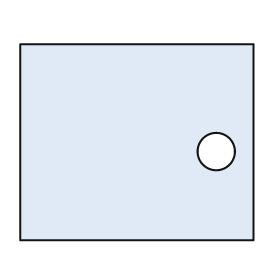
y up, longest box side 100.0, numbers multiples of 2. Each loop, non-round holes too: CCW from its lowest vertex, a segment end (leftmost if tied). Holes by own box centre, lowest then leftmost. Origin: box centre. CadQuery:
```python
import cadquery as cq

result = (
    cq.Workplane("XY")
    .moveTo(-50.0, -42.0)
    .lineTo(50.0, -42.0)
    .lineTo(50.0, 42.0)
    .lineTo(-50.0, 42.0)
    .close()
    .moveTo(34.0, -4.0)
    .circle(8.0)
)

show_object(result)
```